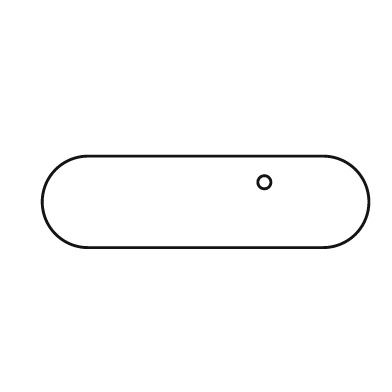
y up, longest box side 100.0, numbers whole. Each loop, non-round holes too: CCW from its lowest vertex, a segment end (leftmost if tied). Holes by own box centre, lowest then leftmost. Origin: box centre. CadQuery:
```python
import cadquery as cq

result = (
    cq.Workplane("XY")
    .moveTo(-36.0, -14.0)
    .lineTo(36.0, -14.0)
    .threePointArc((50.0, 0.0), (36.0, 14.0))
    .lineTo(-36.0, 14.0)
    .threePointArc((-50.0, 0.0), (-36.0, -14.0))
    .close()
    .moveTo(18.0, 6.0)
    .circle(2.0)
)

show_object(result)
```